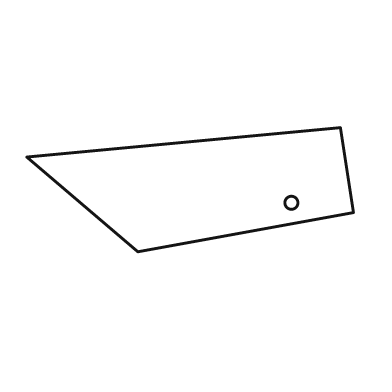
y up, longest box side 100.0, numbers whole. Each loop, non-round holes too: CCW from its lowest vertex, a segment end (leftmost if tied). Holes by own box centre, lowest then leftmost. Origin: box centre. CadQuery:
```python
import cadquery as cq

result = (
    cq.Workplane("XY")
    .moveTo(-16.0, -19.0)
    .lineTo(50.0, -7.0)
    .lineTo(46.0, 19.0)
    .lineTo(-50.0, 10.0)
    .close()
    .moveTo(31.0, -4.0)
    .circle(2.0)
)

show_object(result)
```